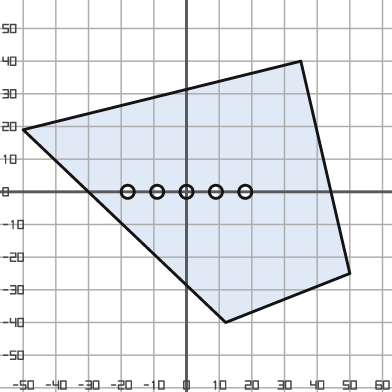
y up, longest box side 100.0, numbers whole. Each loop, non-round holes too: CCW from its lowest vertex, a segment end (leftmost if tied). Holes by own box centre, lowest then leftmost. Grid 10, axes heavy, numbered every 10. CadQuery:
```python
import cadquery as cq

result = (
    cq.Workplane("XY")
    .moveTo(12.0, -40.0)
    .lineTo(50.0, -25.0)
    .lineTo(35.0, 40.0)
    .lineTo(-50.0, 19.0)
    .close()
    .moveTo(-18.0, 0.0)
    .circle(2.0)
    .moveTo(-9.0, 0.0)
    .circle(2.0)
    .moveTo(0.0, 0.0)
    .circle(2.0)
    .moveTo(9.0, 0.0)
    .circle(2.0)
    .moveTo(18.0, 0.0)
    .circle(2.0)
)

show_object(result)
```